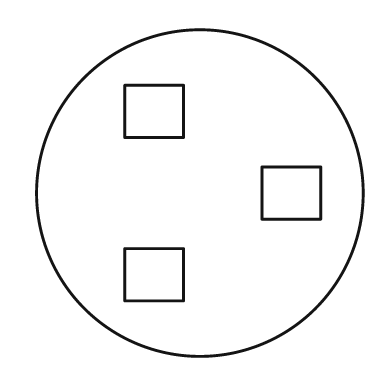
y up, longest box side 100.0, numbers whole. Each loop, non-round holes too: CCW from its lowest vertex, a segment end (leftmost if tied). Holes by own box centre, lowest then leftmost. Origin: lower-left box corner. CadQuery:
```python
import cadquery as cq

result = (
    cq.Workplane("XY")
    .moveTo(50.0, 50.0)
    .circle(50.0)
    .moveTo(27.0, 17.0)
    .lineTo(45.0, 17.0)
    .lineTo(45.0, 33.0)
    .lineTo(27.0, 33.0)
    .close()
    .moveTo(69.0, 42.0)
    .lineTo(87.0, 42.0)
    .lineTo(87.0, 58.0)
    .lineTo(69.0, 58.0)
    .close()
    .moveTo(27.0, 67.0)
    .lineTo(45.0, 67.0)
    .lineTo(45.0, 83.0)
    .lineTo(27.0, 83.0)
    .close()
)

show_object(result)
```